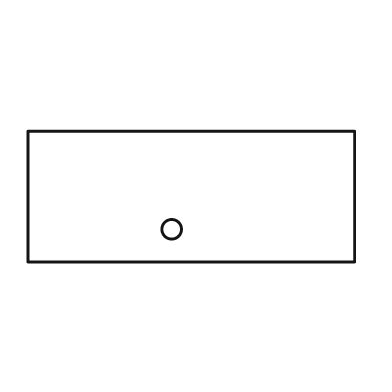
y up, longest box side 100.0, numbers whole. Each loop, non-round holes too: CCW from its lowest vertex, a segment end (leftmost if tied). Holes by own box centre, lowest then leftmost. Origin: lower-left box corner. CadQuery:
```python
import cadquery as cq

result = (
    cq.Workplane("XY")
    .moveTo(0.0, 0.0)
    .lineTo(100.0, 0.0)
    .lineTo(100.0, 40.0)
    .lineTo(0.0, 40.0)
    .close()
    .moveTo(44.0, 10.0)
    .circle(3.0)
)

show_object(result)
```